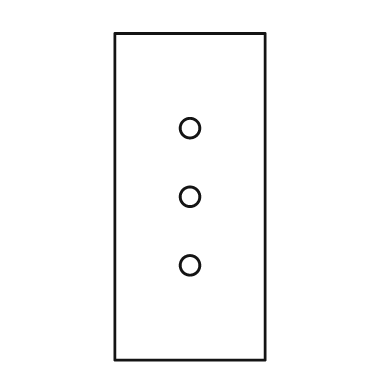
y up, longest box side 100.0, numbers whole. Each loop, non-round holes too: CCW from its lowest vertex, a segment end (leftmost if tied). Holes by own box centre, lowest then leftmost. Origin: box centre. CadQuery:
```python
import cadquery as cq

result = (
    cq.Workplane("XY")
    .moveTo(-23.0, -50.0)
    .lineTo(23.0, -50.0)
    .lineTo(23.0, 50.0)
    .lineTo(-23.0, 50.0)
    .close()
    .moveTo(0.0, -21.0)
    .circle(3.0)
    .moveTo(0.0, 0.0)
    .circle(3.0)
    .moveTo(0.0, 21.0)
    .circle(3.0)
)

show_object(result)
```